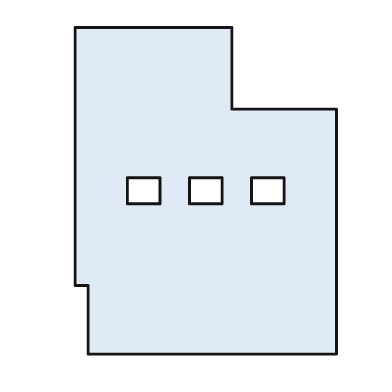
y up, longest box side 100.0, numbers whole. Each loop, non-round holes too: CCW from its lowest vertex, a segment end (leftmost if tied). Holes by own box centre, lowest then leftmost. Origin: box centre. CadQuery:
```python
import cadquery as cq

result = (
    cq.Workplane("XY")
    .moveTo(-36.0, -50.0)
    .lineTo(40.0, -50.0)
    .lineTo(40.0, 25.0)
    .lineTo(8.0, 25.0)
    .lineTo(8.0, 50.0)
    .lineTo(-40.0, 50.0)
    .lineTo(-40.0, -29.0)
    .lineTo(-36.0, -29.0)
    .close()
    .moveTo(-24.0, -4.0)
    .lineTo(-14.0, -4.0)
    .lineTo(-14.0, 4.0)
    .lineTo(-24.0, 4.0)
    .close()
    .moveTo(-5.0, -4.0)
    .lineTo(5.0, -4.0)
    .lineTo(5.0, 4.0)
    .lineTo(-5.0, 4.0)
    .close()
    .moveTo(14.0, -4.0)
    .lineTo(24.0, -4.0)
    .lineTo(24.0, 4.0)
    .lineTo(14.0, 4.0)
    .close()
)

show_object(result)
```